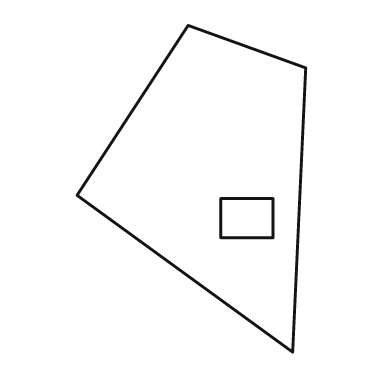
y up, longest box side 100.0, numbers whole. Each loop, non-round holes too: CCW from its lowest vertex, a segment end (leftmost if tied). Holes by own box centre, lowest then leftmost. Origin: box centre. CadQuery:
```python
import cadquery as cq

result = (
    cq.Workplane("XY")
    .moveTo(31.0, -50.0)
    .lineTo(35.0, 37.0)
    .lineTo(-1.0, 50.0)
    .lineTo(-35.0, -2.0)
    .close()
    .moveTo(9.0, -15.0)
    .lineTo(25.0, -15.0)
    .lineTo(25.0, -3.0)
    .lineTo(9.0, -3.0)
    .close()
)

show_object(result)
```